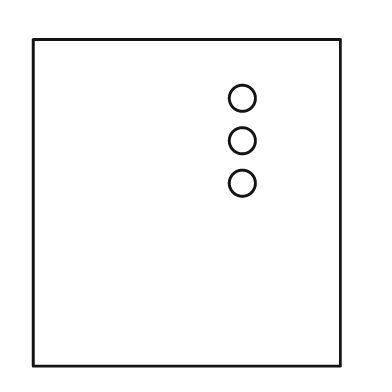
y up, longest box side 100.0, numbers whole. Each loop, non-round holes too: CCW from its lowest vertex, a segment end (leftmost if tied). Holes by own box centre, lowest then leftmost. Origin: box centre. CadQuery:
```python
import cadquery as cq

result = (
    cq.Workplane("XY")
    .moveTo(-47.0, -50.0)
    .lineTo(47.0, -50.0)
    .lineTo(47.0, 50.0)
    .lineTo(-47.0, 50.0)
    .close()
    .moveTo(17.0, 6.0)
    .circle(4.0)
    .moveTo(17.0, 19.0)
    .circle(4.0)
    .moveTo(17.0, 32.0)
    .circle(4.0)
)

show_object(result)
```